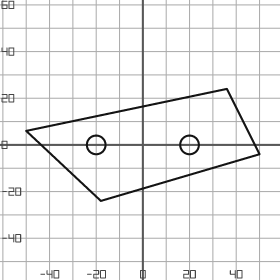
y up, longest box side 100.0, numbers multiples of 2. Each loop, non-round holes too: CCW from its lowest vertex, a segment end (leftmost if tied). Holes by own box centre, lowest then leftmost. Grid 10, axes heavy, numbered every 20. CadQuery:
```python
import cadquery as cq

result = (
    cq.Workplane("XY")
    .moveTo(-18.0, -24.0)
    .lineTo(50.0, -4.0)
    .lineTo(36.0, 24.0)
    .lineTo(-50.0, 6.0)
    .close()
    .moveTo(-20.0, 0.0)
    .circle(4.0)
    .moveTo(20.0, 0.0)
    .circle(4.0)
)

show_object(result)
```